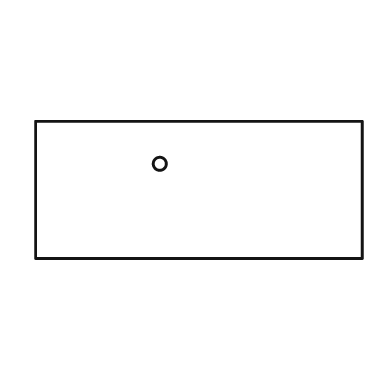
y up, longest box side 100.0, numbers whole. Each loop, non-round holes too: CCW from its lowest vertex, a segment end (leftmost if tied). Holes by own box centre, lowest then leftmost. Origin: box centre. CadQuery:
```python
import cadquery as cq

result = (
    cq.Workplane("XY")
    .moveTo(-50.0, -21.0)
    .lineTo(50.0, -21.0)
    .lineTo(50.0, 21.0)
    .lineTo(-50.0, 21.0)
    .close()
    .moveTo(-12.0, 8.0)
    .circle(2.0)
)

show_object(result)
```